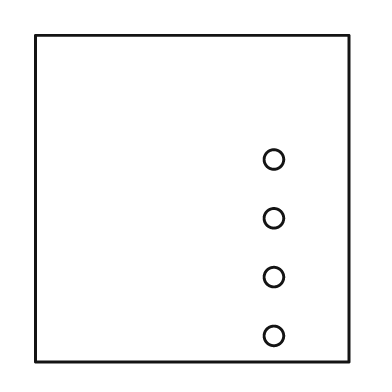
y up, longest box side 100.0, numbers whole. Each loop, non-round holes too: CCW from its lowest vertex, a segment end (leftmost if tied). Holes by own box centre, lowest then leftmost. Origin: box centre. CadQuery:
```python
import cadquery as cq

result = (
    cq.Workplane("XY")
    .moveTo(-48.0, -50.0)
    .lineTo(48.0, -50.0)
    .lineTo(48.0, 50.0)
    .lineTo(-48.0, 50.0)
    .close()
    .moveTo(25.0, -42.0)
    .circle(3.0)
    .moveTo(25.0, -24.0)
    .circle(3.0)
    .moveTo(25.0, -6.0)
    .circle(3.0)
    .moveTo(25.0, 12.0)
    .circle(3.0)
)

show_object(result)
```